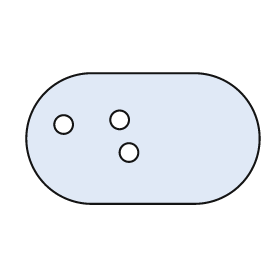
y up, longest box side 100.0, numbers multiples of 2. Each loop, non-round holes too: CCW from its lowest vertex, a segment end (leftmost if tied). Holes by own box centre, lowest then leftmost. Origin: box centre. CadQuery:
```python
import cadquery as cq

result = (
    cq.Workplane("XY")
    .moveTo(-22.0, -28.0)
    .lineTo(22.0, -28.0)
    .threePointArc((50.0, 0.0), (22.0, 28.0))
    .lineTo(-22.0, 28.0)
    .threePointArc((-50.0, 0.0), (-22.0, -28.0))
    .close()
    .moveTo(-6.0, -6.0)
    .circle(4.0)
    .moveTo(-34.0, 6.0)
    .circle(4.0)
    .moveTo(-10.0, 8.0)
    .circle(4.0)
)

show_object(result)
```